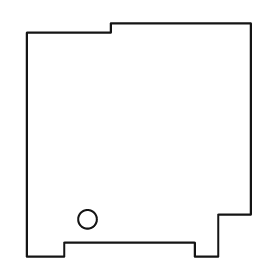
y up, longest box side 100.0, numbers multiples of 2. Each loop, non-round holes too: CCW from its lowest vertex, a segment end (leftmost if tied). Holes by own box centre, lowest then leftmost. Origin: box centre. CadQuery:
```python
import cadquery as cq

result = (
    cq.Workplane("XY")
    .moveTo(-48.0, -50.0)
    .lineTo(-32.0, -50.0)
    .lineTo(-32.0, -44.0)
    .lineTo(24.0, -44.0)
    .lineTo(24.0, -50.0)
    .lineTo(34.0, -50.0)
    .lineTo(34.0, -32.0)
    .lineTo(48.0, -32.0)
    .lineTo(48.0, 50.0)
    .lineTo(-12.0, 50.0)
    .lineTo(-12.0, 46.0)
    .lineTo(-48.0, 46.0)
    .close()
    .moveTo(-22.0, -34.0)
    .circle(4.0)
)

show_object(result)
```